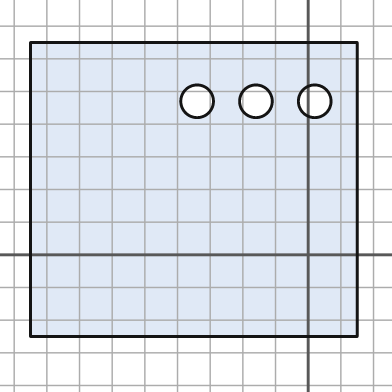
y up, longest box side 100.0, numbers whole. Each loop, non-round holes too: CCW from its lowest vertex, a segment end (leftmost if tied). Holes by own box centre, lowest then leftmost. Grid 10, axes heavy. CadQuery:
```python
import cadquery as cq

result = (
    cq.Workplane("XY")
    .moveTo(-85.0, -25.0)
    .lineTo(15.0, -25.0)
    .lineTo(15.0, 65.0)
    .lineTo(-85.0, 65.0)
    .close()
    .moveTo(-34.0, 47.0)
    .circle(5.0)
    .moveTo(-16.0, 47.0)
    .circle(5.0)
    .moveTo(2.0, 47.0)
    .circle(5.0)
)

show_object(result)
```